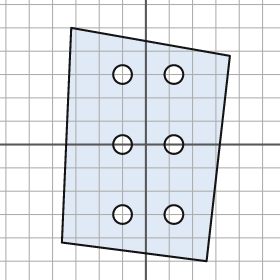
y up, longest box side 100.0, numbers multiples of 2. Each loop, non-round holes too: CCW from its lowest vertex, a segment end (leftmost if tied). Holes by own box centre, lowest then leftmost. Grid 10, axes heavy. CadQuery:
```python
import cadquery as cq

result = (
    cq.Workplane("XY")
    .moveTo(26.0, -50.0)
    .lineTo(36.0, 38.0)
    .lineTo(-32.0, 50.0)
    .lineTo(-36.0, -42.0)
    .close()
    .moveTo(-10.0, -30.0)
    .circle(4.0)
    .moveTo(12.0, -30.0)
    .circle(4.0)
    .moveTo(-10.0, 0.0)
    .circle(4.0)
    .moveTo(12.0, 0.0)
    .circle(4.0)
    .moveTo(-10.0, 30.0)
    .circle(4.0)
    .moveTo(12.0, 30.0)
    .circle(4.0)
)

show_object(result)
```